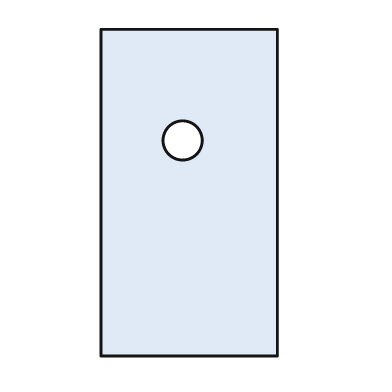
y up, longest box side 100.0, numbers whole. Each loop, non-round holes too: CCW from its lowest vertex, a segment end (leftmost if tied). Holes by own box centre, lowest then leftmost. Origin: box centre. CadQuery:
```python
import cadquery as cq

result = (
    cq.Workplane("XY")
    .moveTo(-27.0, -50.0)
    .lineTo(27.0, -50.0)
    .lineTo(27.0, 50.0)
    .lineTo(-27.0, 50.0)
    .close()
    .moveTo(-2.0, 16.0)
    .circle(6.0)
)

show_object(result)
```